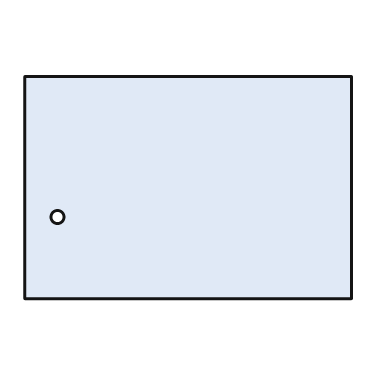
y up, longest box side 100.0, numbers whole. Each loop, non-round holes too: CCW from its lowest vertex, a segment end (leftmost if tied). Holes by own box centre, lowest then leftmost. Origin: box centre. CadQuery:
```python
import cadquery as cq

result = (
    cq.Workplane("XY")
    .moveTo(-50.0, -34.0)
    .lineTo(50.0, -34.0)
    .lineTo(50.0, 34.0)
    .lineTo(-50.0, 34.0)
    .close()
    .moveTo(-40.0, -9.0)
    .circle(2.0)
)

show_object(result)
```